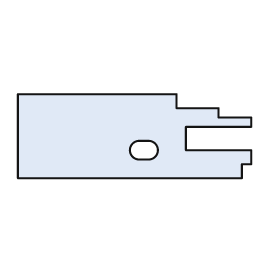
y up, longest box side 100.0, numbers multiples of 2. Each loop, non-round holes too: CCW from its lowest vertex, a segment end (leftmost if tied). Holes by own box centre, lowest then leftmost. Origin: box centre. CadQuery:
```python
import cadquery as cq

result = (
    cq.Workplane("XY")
    .moveTo(-50.0, -18.0)
    .lineTo(46.0, -18.0)
    .lineTo(46.0, -12.0)
    .lineTo(50.0, -12.0)
    .lineTo(50.0, -6.0)
    .lineTo(22.0, -6.0)
    .lineTo(22.0, 4.0)
    .lineTo(50.0, 4.0)
    .lineTo(50.0, 8.0)
    .lineTo(36.0, 8.0)
    .lineTo(36.0, 12.0)
    .lineTo(18.0, 12.0)
    .lineTo(18.0, 18.0)
    .lineTo(-50.0, 18.0)
    .close()
    .moveTo(2.0, -10.0)
    .lineTo(6.0, -10.0)
    .threePointArc((10.0, -6.0), (6.0, -2.0))
    .lineTo(2.0, -2.0)
    .threePointArc((-2.0, -6.0), (2.0, -10.0))
    .close()
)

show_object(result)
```